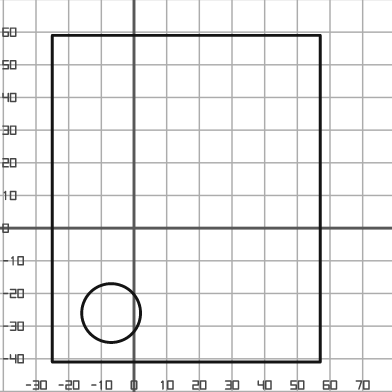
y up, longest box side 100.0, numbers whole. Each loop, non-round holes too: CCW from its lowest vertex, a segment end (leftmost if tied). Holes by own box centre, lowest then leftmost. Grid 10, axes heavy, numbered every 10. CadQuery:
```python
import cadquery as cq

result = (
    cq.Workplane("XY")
    .moveTo(-25.0, -41.0)
    .lineTo(57.0, -41.0)
    .lineTo(57.0, 59.0)
    .lineTo(-25.0, 59.0)
    .close()
    .moveTo(-7.0, -26.0)
    .circle(9.0)
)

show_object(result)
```